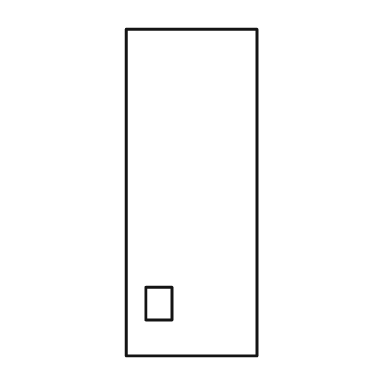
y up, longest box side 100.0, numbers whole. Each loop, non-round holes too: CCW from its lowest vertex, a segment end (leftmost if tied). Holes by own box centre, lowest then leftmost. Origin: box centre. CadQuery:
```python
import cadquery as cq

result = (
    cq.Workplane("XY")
    .moveTo(-20.0, -50.0)
    .lineTo(20.0, -50.0)
    .lineTo(20.0, 50.0)
    .lineTo(-20.0, 50.0)
    .close()
    .moveTo(-14.0, -39.0)
    .lineTo(-6.0, -39.0)
    .lineTo(-6.0, -29.0)
    .lineTo(-14.0, -29.0)
    .close()
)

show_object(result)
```